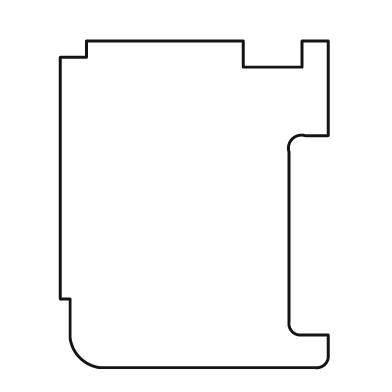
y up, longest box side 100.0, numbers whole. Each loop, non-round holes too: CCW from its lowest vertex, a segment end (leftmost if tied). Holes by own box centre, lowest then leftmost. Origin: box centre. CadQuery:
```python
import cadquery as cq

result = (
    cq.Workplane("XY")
    .moveTo(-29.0, -50.0)
    .lineTo(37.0, -50.0)
    .threePointArc((40.0, -49.0), (41.0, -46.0))
    .lineTo(41.0, -40.0)
    .lineTo(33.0, -40.0)
    .threePointArc((30.0, -39.0), (29.0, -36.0))
    .lineTo(29.0, 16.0)
    .threePointArc((30.0, 20.0), (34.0, 21.0))
    .lineTo(41.0, 21.0)
    .lineTo(41.0, 50.0)
    .lineTo(33.0, 50.0)
    .lineTo(33.0, 42.0)
    .lineTo(15.0, 42.0)
    .lineTo(15.0, 50.0)
    .lineTo(-33.0, 50.0)
    .lineTo(-33.0, 45.0)
    .lineTo(-41.0, 45.0)
    .lineTo(-41.0, -29.0)
    .lineTo(-38.0, -29.0)
    .lineTo(-38.0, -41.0)
    .threePointArc((-35.0, -47.0), (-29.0, -50.0))
    .close()
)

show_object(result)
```